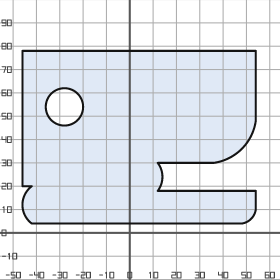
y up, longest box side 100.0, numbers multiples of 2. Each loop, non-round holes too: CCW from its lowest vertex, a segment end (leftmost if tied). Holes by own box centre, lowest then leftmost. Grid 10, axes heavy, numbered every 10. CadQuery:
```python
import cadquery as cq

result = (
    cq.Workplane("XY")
    .moveTo(-42.0, 4.0)
    .lineTo(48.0, 4.0)
    .threePointArc((52.0, 6.0), (54.0, 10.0))
    .lineTo(54.0, 18.0)
    .lineTo(12.0, 18.0)
    .threePointArc((14.0, 24.0), (12.0, 30.0))
    .lineTo(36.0, 30.0)
    .threePointArc((48.0, 36.0), (54.0, 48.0))
    .lineTo(54.0, 78.0)
    .lineTo(-46.0, 78.0)
    .lineTo(-46.0, 20.0)
    .lineTo(-42.0, 20.0)
    .threePointArc((-46.0, 12.0), (-42.0, 4.0))
    .close()
    .moveTo(-28.0, 54.0)
    .circle(8.0)
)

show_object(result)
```